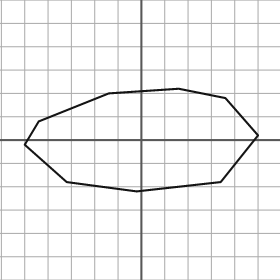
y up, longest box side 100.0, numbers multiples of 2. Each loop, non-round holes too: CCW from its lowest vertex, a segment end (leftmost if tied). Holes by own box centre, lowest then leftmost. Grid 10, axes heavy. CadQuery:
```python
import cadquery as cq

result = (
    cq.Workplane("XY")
    .moveTo(-2.0, -22.0)
    .lineTo(34.0, -18.0)
    .lineTo(50.0, 2.0)
    .lineTo(36.0, 18.0)
    .lineTo(16.0, 22.0)
    .lineTo(-14.0, 20.0)
    .lineTo(-44.0, 8.0)
    .lineTo(-50.0, -2.0)
    .lineTo(-32.0, -18.0)
    .close()
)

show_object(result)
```